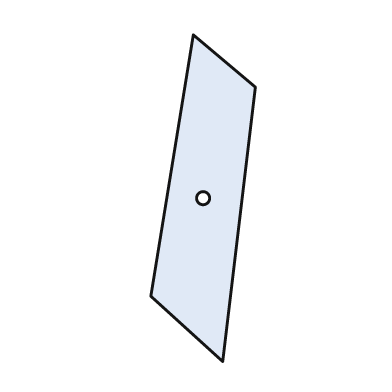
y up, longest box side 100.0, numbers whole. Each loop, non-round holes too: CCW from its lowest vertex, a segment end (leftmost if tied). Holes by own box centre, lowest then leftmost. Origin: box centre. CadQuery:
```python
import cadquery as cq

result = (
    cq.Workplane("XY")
    .moveTo(6.0, -50.0)
    .lineTo(16.0, 34.0)
    .lineTo(-3.0, 50.0)
    .lineTo(-16.0, -30.0)
    .close()
    .moveTo(0.0, 0.0)
    .circle(2.0)
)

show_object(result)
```